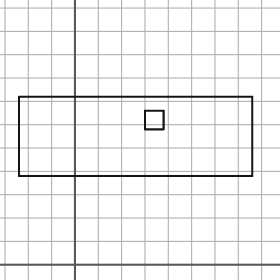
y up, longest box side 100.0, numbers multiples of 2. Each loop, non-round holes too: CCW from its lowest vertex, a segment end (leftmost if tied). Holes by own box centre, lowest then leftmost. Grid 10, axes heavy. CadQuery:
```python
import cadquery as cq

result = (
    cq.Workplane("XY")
    .moveTo(-24.0, 38.0)
    .lineTo(76.0, 38.0)
    .lineTo(76.0, 72.0)
    .lineTo(-24.0, 72.0)
    .close()
    .moveTo(30.0, 58.0)
    .lineTo(38.0, 58.0)
    .lineTo(38.0, 66.0)
    .lineTo(30.0, 66.0)
    .close()
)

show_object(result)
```